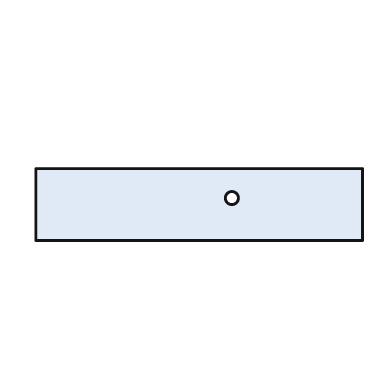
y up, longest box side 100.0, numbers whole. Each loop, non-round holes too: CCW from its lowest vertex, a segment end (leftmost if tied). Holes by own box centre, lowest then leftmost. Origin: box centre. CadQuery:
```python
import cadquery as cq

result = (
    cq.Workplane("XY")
    .moveTo(-50.0, -11.0)
    .lineTo(50.0, -11.0)
    .lineTo(50.0, 11.0)
    .lineTo(-50.0, 11.0)
    .close()
    .moveTo(10.0, 2.0)
    .circle(2.0)
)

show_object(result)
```